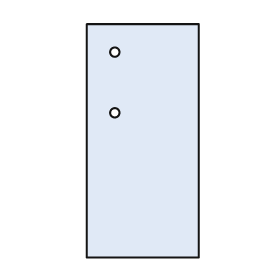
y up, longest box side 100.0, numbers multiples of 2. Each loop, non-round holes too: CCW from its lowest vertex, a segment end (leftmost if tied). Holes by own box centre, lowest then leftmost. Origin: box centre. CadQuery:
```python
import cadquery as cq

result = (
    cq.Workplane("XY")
    .moveTo(-24.0, -50.0)
    .lineTo(24.0, -50.0)
    .lineTo(24.0, 50.0)
    .lineTo(-24.0, 50.0)
    .close()
    .moveTo(-12.0, 12.0)
    .circle(2.0)
    .moveTo(-12.0, 38.0)
    .circle(2.0)
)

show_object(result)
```